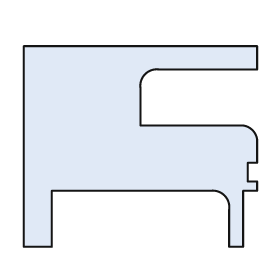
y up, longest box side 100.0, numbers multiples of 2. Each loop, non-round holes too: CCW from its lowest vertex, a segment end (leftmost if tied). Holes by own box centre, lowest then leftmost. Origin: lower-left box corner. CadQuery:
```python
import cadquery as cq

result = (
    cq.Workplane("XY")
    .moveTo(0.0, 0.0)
    .lineTo(12.0, 0.0)
    .lineTo(12.0, 24.0)
    .lineTo(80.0, 24.0)
    .threePointArc((86.0, 22.0), (88.0, 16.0))
    .lineTo(88.0, 0.0)
    .lineTo(94.0, 0.0)
    .lineTo(94.0, 24.0)
    .lineTo(100.0, 24.0)
    .lineTo(100.0, 28.0)
    .lineTo(96.0, 28.0)
    .lineTo(96.0, 36.0)
    .lineTo(100.0, 36.0)
    .lineTo(100.0, 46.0)
    .threePointArc((98.0, 50.0), (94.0, 52.0))
    .lineTo(50.0, 52.0)
    .lineTo(50.0, 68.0)
    .threePointArc((52.0, 74.0), (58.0, 76.0))
    .lineTo(100.0, 76.0)
    .lineTo(100.0, 86.0)
    .lineTo(0.0, 86.0)
    .close()
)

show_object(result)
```